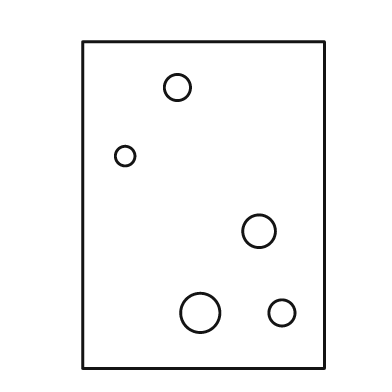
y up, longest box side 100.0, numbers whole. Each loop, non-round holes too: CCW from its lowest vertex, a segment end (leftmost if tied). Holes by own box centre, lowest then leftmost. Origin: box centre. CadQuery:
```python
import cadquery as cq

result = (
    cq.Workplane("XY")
    .moveTo(-37.0, -50.0)
    .lineTo(37.0, -50.0)
    .lineTo(37.0, 50.0)
    .lineTo(-37.0, 50.0)
    .close()
    .moveTo(-1.0, -33.0)
    .circle(6.0)
    .moveTo(24.0, -33.0)
    .circle(4.0)
    .moveTo(17.0, -8.0)
    .circle(5.0)
    .moveTo(-24.0, 15.0)
    .circle(3.0)
    .moveTo(-8.0, 36.0)
    .circle(4.0)
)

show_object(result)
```